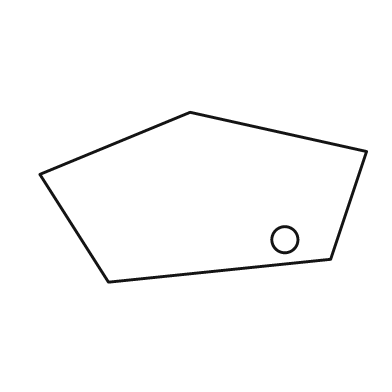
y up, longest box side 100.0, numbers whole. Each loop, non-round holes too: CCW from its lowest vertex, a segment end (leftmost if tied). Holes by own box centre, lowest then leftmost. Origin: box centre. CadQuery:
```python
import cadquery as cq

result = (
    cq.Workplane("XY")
    .moveTo(-29.0, -26.0)
    .lineTo(39.0, -19.0)
    .lineTo(50.0, 14.0)
    .lineTo(-4.0, 26.0)
    .lineTo(-50.0, 7.0)
    .close()
    .moveTo(25.0, -13.0)
    .circle(4.0)
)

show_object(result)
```